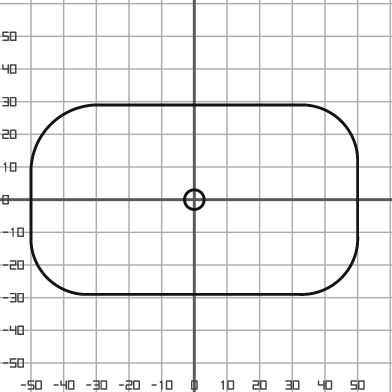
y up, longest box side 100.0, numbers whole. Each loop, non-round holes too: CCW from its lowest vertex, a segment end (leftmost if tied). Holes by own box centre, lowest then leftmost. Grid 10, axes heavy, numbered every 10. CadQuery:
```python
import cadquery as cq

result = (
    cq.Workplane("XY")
    .moveTo(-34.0, -29.0)
    .lineTo(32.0, -29.0)
    .threePointArc((45.0, -24.0), (50.0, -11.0))
    .lineTo(50.0, 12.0)
    .threePointArc((45.0, 24.0), (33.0, 29.0))
    .lineTo(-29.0, 29.0)
    .threePointArc((-44.0, 23.0), (-50.0, 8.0))
    .lineTo(-50.0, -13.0)
    .threePointArc((-45.0, -24.0), (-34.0, -29.0))
    .close()
    .moveTo(0.0, 0.0)
    .circle(3.0)
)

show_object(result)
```